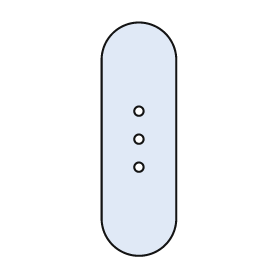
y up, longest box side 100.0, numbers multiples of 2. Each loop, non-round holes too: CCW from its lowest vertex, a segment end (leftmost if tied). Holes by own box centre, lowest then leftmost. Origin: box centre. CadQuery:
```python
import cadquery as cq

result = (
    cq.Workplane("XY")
    .moveTo(-16.0, -34.0)
    .threePointArc((0.0, -50.0), (16.0, -34.0))
    .lineTo(16.0, 34.0)
    .threePointArc((0.0, 50.0), (-16.0, 34.0))
    .close()
    .moveTo(0.0, -12.0)
    .circle(2.0)
    .moveTo(0.0, 0.0)
    .circle(2.0)
    .moveTo(0.0, 12.0)
    .circle(2.0)
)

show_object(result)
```